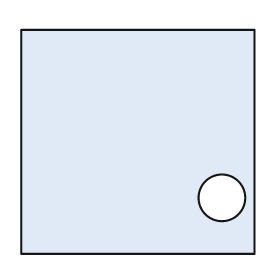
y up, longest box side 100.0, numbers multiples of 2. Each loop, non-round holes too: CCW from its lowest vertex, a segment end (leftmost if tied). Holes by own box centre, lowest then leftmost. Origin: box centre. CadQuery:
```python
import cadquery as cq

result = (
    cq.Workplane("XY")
    .moveTo(-50.0, -48.0)
    .lineTo(50.0, -48.0)
    .lineTo(50.0, 48.0)
    .lineTo(-50.0, 48.0)
    .close()
    .moveTo(36.0, -24.0)
    .circle(10.0)
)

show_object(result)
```